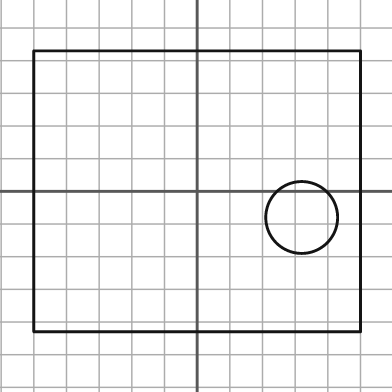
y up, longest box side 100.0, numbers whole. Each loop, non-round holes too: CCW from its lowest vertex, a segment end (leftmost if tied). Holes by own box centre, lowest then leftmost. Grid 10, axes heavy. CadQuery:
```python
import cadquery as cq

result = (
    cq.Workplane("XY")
    .moveTo(-50.0, -43.0)
    .lineTo(50.0, -43.0)
    .lineTo(50.0, 43.0)
    .lineTo(-50.0, 43.0)
    .close()
    .moveTo(32.0, -8.0)
    .circle(11.0)
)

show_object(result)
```